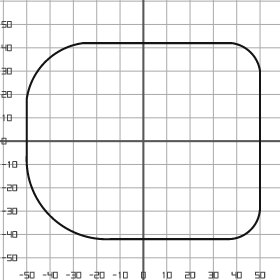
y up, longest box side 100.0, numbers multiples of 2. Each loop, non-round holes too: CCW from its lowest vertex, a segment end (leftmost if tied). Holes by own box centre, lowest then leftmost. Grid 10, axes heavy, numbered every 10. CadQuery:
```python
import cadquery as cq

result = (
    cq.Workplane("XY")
    .moveTo(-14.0, -42.0)
    .lineTo(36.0, -42.0)
    .threePointArc((46.0, -38.0), (50.0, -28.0))
    .lineTo(50.0, 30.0)
    .threePointArc((46.0, 38.0), (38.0, 42.0))
    .lineTo(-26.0, 42.0)
    .threePointArc((-42.0, 34.0), (-50.0, 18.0))
    .lineTo(-50.0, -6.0)
    .threePointArc((-40.0, -32.0), (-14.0, -42.0))
    .close()
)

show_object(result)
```